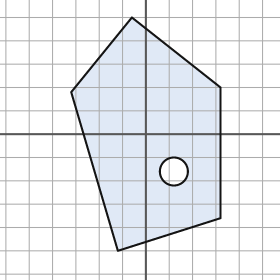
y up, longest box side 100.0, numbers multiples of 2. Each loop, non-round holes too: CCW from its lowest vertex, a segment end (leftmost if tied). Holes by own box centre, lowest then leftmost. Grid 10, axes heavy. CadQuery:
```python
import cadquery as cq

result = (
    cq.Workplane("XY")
    .moveTo(-12.0, -50.0)
    .lineTo(32.0, -36.0)
    .lineTo(32.0, 20.0)
    .lineTo(-6.0, 50.0)
    .lineTo(-32.0, 18.0)
    .close()
    .moveTo(12.0, -16.0)
    .circle(6.0)
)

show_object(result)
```